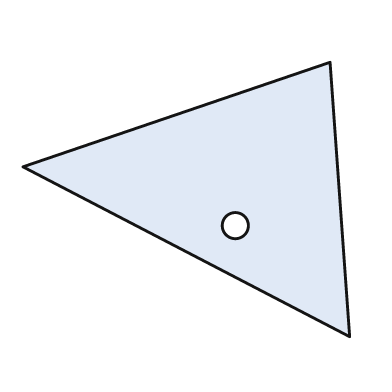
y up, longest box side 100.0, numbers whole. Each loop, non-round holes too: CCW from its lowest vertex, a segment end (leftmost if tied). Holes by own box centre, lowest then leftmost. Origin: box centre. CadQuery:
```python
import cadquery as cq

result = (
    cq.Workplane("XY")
    .moveTo(50.0, -42.0)
    .lineTo(44.0, 42.0)
    .lineTo(-50.0, 10.0)
    .close()
    .moveTo(15.0, -8.0)
    .circle(4.0)
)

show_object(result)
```